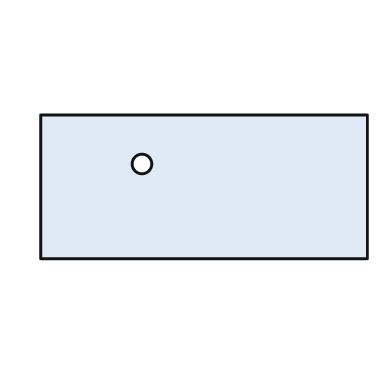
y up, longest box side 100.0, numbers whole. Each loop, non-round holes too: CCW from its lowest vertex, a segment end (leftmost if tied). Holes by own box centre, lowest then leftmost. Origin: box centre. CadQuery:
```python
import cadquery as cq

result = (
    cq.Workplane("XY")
    .moveTo(-50.0, -22.0)
    .lineTo(50.0, -22.0)
    .lineTo(50.0, 22.0)
    .lineTo(-50.0, 22.0)
    .close()
    .moveTo(-19.0, 7.0)
    .circle(3.0)
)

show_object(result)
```